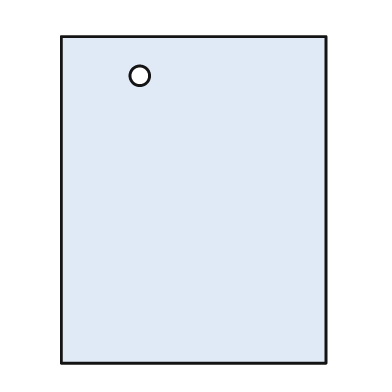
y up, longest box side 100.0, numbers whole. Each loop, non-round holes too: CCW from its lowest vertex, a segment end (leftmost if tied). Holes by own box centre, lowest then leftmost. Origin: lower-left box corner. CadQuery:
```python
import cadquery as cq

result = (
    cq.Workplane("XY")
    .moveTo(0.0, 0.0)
    .lineTo(81.0, 0.0)
    .lineTo(81.0, 100.0)
    .lineTo(0.0, 100.0)
    .close()
    .moveTo(24.0, 88.0)
    .circle(3.0)
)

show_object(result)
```